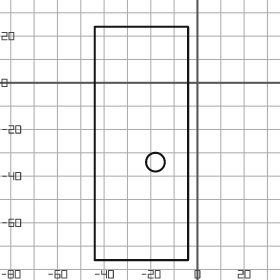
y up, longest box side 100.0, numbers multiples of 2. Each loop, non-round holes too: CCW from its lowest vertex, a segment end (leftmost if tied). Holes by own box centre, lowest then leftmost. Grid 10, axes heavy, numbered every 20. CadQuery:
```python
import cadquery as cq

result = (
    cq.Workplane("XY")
    .moveTo(-44.0, -76.0)
    .lineTo(-4.0, -76.0)
    .lineTo(-4.0, 24.0)
    .lineTo(-44.0, 24.0)
    .close()
    .moveTo(-18.0, -34.0)
    .circle(4.0)
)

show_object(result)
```